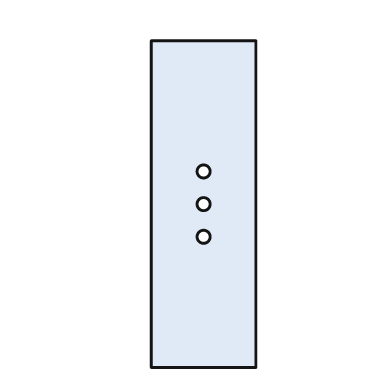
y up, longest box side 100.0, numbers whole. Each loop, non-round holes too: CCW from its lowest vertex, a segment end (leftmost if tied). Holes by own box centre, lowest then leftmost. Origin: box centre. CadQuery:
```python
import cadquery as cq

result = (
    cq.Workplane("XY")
    .moveTo(-16.0, -50.0)
    .lineTo(16.0, -50.0)
    .lineTo(16.0, 50.0)
    .lineTo(-16.0, 50.0)
    .close()
    .moveTo(0.0, -10.0)
    .circle(2.0)
    .moveTo(0.0, 0.0)
    .circle(2.0)
    .moveTo(0.0, 10.0)
    .circle(2.0)
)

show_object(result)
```